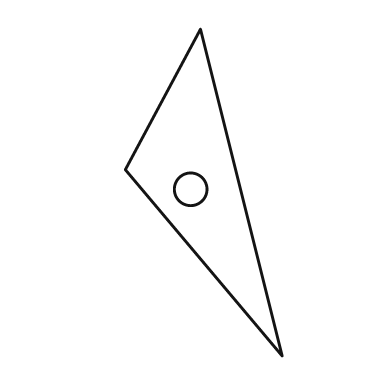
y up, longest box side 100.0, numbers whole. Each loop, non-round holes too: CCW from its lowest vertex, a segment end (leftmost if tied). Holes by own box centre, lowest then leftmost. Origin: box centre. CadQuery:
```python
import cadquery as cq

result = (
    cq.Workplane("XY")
    .moveTo(24.0, -50.0)
    .lineTo(-1.0, 50.0)
    .lineTo(-24.0, 7.0)
    .close()
    .moveTo(-4.0, 1.0)
    .circle(5.0)
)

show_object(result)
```